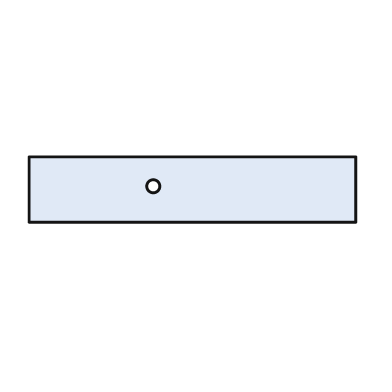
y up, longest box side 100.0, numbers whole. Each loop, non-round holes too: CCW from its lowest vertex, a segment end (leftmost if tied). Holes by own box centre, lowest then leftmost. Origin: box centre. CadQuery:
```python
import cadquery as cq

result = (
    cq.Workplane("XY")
    .moveTo(-50.0, -10.0)
    .lineTo(50.0, -10.0)
    .lineTo(50.0, 10.0)
    .lineTo(-50.0, 10.0)
    .close()
    .moveTo(-12.0, 1.0)
    .circle(2.0)
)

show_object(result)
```